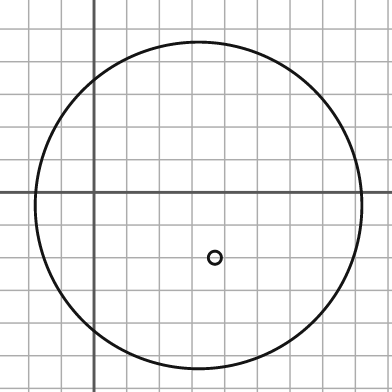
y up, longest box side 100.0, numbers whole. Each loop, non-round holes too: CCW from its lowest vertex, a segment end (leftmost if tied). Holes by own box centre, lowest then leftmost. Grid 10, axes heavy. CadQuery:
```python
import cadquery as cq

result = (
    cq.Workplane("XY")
    .moveTo(32.0, -4.0)
    .circle(50.0)
    .moveTo(37.0, -20.0)
    .circle(2.0)
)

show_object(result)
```